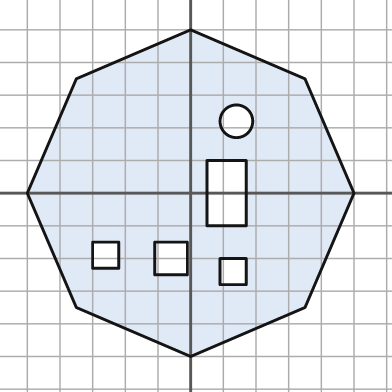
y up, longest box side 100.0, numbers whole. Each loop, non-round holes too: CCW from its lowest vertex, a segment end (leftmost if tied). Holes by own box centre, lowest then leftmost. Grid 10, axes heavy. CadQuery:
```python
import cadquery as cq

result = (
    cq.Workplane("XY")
    .moveTo(0.0, -50.0)
    .lineTo(35.0, -35.0)
    .lineTo(50.0, 0.0)
    .lineTo(35.0, 35.0)
    .lineTo(0.0, 50.0)
    .lineTo(-35.0, 35.0)
    .lineTo(-50.0, 0.0)
    .lineTo(-35.0, -35.0)
    .close()
    .moveTo(9.0, -28.0)
    .lineTo(17.0, -28.0)
    .lineTo(17.0, -20.0)
    .lineTo(9.0, -20.0)
    .close()
    .moveTo(-11.0, -25.0)
    .lineTo(-1.0, -25.0)
    .lineTo(-1.0, -15.0)
    .lineTo(-11.0, -15.0)
    .close()
    .moveTo(-30.0, -23.0)
    .lineTo(-22.0, -23.0)
    .lineTo(-22.0, -15.0)
    .lineTo(-30.0, -15.0)
    .close()
    .moveTo(5.0, -10.0)
    .lineTo(17.0, -10.0)
    .lineTo(17.0, 10.0)
    .lineTo(5.0, 10.0)
    .close()
    .moveTo(14.0, 22.0)
    .circle(5.0)
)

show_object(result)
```